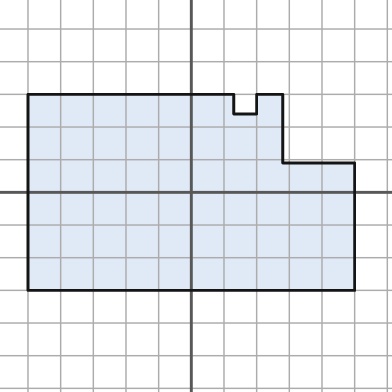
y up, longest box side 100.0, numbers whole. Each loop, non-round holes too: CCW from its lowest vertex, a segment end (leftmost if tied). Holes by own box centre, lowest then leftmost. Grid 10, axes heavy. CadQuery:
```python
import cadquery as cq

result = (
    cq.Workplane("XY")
    .moveTo(-50.0, -30.0)
    .lineTo(50.0, -30.0)
    .lineTo(50.0, 9.0)
    .lineTo(28.0, 9.0)
    .lineTo(28.0, 30.0)
    .lineTo(20.0, 30.0)
    .lineTo(20.0, 24.0)
    .lineTo(13.0, 24.0)
    .lineTo(13.0, 30.0)
    .lineTo(-50.0, 30.0)
    .close()
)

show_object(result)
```